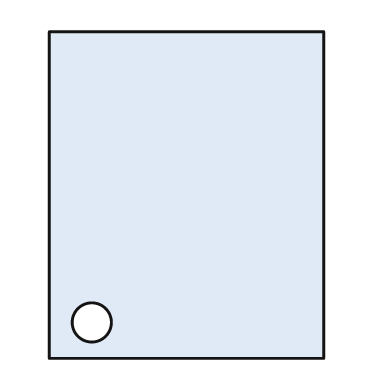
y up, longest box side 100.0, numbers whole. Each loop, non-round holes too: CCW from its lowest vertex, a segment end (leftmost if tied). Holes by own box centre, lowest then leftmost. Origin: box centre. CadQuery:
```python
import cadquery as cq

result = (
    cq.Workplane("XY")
    .moveTo(-42.0, -50.0)
    .lineTo(42.0, -50.0)
    .lineTo(42.0, 50.0)
    .lineTo(-42.0, 50.0)
    .close()
    .moveTo(-29.0, -39.0)
    .circle(6.0)
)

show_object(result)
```